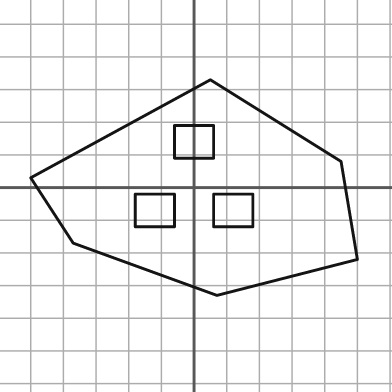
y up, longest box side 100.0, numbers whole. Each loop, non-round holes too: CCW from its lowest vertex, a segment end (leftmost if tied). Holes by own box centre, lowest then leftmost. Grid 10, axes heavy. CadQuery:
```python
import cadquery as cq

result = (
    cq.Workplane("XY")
    .moveTo(7.0, -33.0)
    .lineTo(50.0, -22.0)
    .lineTo(45.0, 8.0)
    .lineTo(5.0, 33.0)
    .lineTo(-50.0, 3.0)
    .lineTo(-37.0, -17.0)
    .close()
    .moveTo(-18.0, -12.0)
    .lineTo(-6.0, -12.0)
    .lineTo(-6.0, -2.0)
    .lineTo(-18.0, -2.0)
    .close()
    .moveTo(6.0, -12.0)
    .lineTo(18.0, -12.0)
    .lineTo(18.0, -2.0)
    .lineTo(6.0, -2.0)
    .close()
    .moveTo(-6.0, 9.0)
    .lineTo(6.0, 9.0)
    .lineTo(6.0, 19.0)
    .lineTo(-6.0, 19.0)
    .close()
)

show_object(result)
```